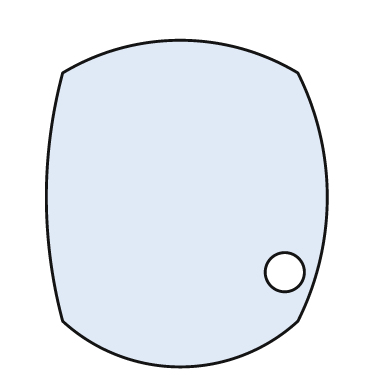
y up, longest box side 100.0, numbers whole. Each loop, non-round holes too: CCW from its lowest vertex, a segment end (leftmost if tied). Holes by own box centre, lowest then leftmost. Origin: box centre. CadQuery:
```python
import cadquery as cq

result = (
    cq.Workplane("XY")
    .moveTo(-38.0, -36.0)
    .threePointArc((-2.0, -50.0), (34.0, -36.0))
    .threePointArc((43.0, 2.0), (34.0, 40.0))
    .threePointArc((-2.0, 50.0), (-38.0, 40.0))
    .threePointArc((-43.0, 2.0), (-38.0, -36.0))
    .close()
    .moveTo(30.0, -21.0)
    .circle(6.0)
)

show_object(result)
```